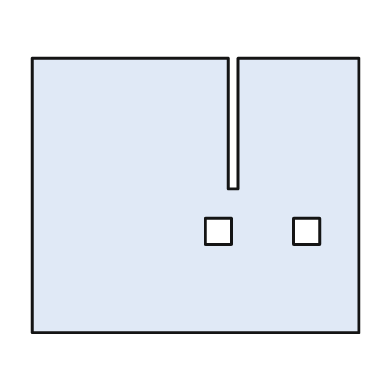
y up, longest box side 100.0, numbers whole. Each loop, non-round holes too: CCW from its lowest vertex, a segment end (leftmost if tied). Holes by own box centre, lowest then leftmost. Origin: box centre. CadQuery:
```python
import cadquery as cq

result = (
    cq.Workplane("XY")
    .moveTo(-50.0, -42.0)
    .lineTo(50.0, -42.0)
    .lineTo(50.0, 42.0)
    .lineTo(13.0, 42.0)
    .lineTo(13.0, 2.0)
    .lineTo(10.0, 2.0)
    .lineTo(10.0, 42.0)
    .lineTo(-50.0, 42.0)
    .close()
    .moveTo(3.0, -15.0)
    .lineTo(11.0, -15.0)
    .lineTo(11.0, -7.0)
    .lineTo(3.0, -7.0)
    .close()
    .moveTo(30.0, -15.0)
    .lineTo(38.0, -15.0)
    .lineTo(38.0, -7.0)
    .lineTo(30.0, -7.0)
    .close()
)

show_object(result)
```